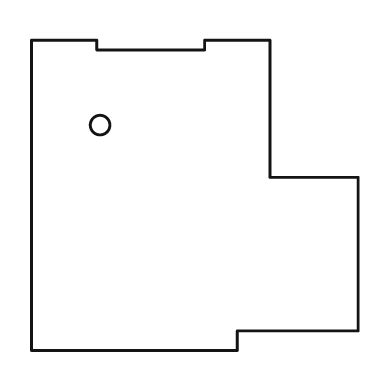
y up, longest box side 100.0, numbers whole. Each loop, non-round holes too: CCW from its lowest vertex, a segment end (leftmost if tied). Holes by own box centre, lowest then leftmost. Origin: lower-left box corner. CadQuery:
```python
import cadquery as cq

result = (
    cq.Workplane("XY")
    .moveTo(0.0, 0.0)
    .lineTo(63.0, 0.0)
    .lineTo(63.0, 6.0)
    .lineTo(100.0, 6.0)
    .lineTo(100.0, 53.0)
    .lineTo(73.0, 53.0)
    .lineTo(73.0, 95.0)
    .lineTo(53.0, 95.0)
    .lineTo(53.0, 92.0)
    .lineTo(20.0, 92.0)
    .lineTo(20.0, 95.0)
    .lineTo(0.0, 95.0)
    .close()
    .moveTo(21.0, 69.0)
    .circle(3.0)
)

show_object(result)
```